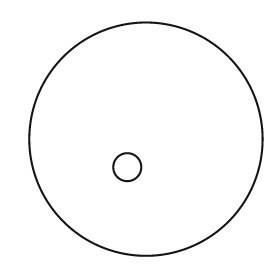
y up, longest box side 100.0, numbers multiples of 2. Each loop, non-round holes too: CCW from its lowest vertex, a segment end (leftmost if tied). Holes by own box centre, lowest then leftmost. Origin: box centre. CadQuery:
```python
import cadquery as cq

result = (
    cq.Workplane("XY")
    .moveTo(0.0, 0.0)
    .circle(50.0)
    .moveTo(-8.0, -12.0)
    .circle(6.0)
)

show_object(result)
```